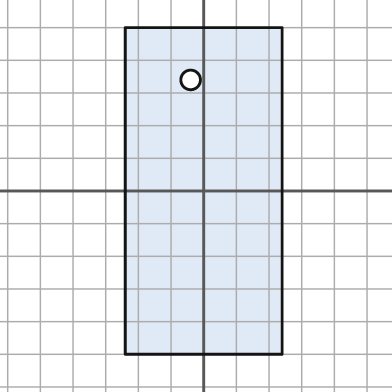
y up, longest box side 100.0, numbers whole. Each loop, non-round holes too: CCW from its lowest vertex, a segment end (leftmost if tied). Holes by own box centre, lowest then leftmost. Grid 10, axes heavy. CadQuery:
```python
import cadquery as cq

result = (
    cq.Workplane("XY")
    .moveTo(-24.0, -50.0)
    .lineTo(24.0, -50.0)
    .lineTo(24.0, 50.0)
    .lineTo(-24.0, 50.0)
    .close()
    .moveTo(-4.0, 34.0)
    .circle(3.0)
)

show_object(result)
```